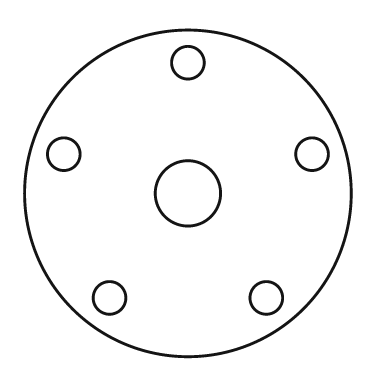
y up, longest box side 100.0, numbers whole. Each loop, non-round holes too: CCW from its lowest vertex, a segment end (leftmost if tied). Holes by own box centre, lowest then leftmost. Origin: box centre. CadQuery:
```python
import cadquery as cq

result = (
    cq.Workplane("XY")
    .moveTo(0.0, 0.0)
    .circle(50.0)
    .moveTo(-24.0, -32.0)
    .circle(5.0)
    .moveTo(24.0, -32.0)
    .circle(5.0)
    .moveTo(0.0, 0.0)
    .circle(10.0)
    .moveTo(-38.0, 12.0)
    .circle(5.0)
    .moveTo(38.0, 12.0)
    .circle(5.0)
    .moveTo(0.0, 40.0)
    .circle(5.0)
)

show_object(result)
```